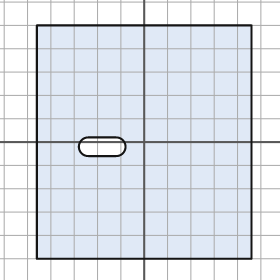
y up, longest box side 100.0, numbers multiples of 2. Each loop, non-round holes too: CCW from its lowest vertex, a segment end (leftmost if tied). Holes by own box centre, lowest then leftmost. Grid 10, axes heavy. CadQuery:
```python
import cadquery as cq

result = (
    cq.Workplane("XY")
    .moveTo(-46.0, -50.0)
    .lineTo(46.0, -50.0)
    .lineTo(46.0, 50.0)
    .lineTo(-46.0, 50.0)
    .close()
    .moveTo(-24.0, -6.0)
    .lineTo(-12.0, -6.0)
    .threePointArc((-8.0, -2.0), (-12.0, 2.0))
    .lineTo(-24.0, 2.0)
    .threePointArc((-28.0, -2.0), (-24.0, -6.0))
    .close()
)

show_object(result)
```